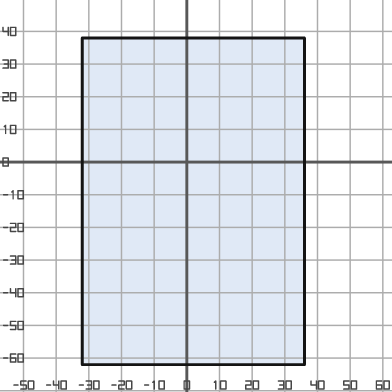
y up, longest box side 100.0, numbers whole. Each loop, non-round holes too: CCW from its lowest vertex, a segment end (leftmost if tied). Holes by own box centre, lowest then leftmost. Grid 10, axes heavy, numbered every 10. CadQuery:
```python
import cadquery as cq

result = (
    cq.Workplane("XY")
    .moveTo(-32.0, -62.0)
    .lineTo(36.0, -62.0)
    .lineTo(36.0, 38.0)
    .lineTo(-32.0, 38.0)
    .close()
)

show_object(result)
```